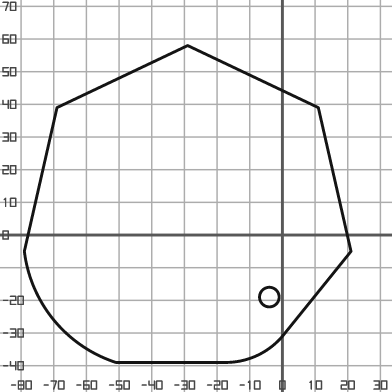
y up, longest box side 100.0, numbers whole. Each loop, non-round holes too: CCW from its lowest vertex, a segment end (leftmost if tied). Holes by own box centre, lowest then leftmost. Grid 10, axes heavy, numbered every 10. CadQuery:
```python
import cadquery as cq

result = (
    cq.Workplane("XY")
    .moveTo(-51.0, -39.0)
    .lineTo(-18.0, -39.0)
    .threePointArc((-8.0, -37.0), (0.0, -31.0))
    .lineTo(21.0, -5.0)
    .lineTo(11.0, 39.0)
    .lineTo(-29.0, 58.0)
    .lineTo(-69.0, 39.0)
    .lineTo(-79.0, -5.0)
    .threePointArc((-70.0, -26.0), (-51.0, -39.0))
    .close()
    .moveTo(-4.0, -19.0)
    .circle(3.0)
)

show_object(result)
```